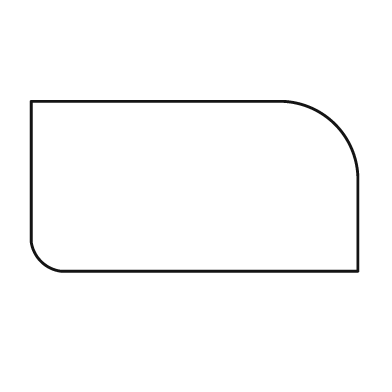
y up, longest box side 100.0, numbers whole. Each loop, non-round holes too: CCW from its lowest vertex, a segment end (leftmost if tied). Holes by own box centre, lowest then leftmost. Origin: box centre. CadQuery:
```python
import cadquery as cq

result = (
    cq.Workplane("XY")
    .moveTo(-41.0, -26.0)
    .lineTo(50.0, -26.0)
    .lineTo(50.0, 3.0)
    .threePointArc((43.0, 19.0), (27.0, 26.0))
    .lineTo(-50.0, 26.0)
    .lineTo(-50.0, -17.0)
    .threePointArc((-47.0, -23.0), (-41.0, -26.0))
    .close()
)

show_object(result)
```